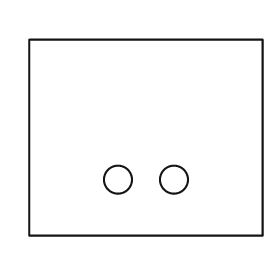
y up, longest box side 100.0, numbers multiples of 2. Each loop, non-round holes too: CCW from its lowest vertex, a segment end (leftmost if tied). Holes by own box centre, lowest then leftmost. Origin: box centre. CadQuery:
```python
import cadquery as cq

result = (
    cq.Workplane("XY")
    .moveTo(-50.0, -42.0)
    .lineTo(50.0, -42.0)
    .lineTo(50.0, 42.0)
    .lineTo(-50.0, 42.0)
    .close()
    .moveTo(-12.0, -18.0)
    .circle(6.0)
    .moveTo(12.0, -18.0)
    .circle(6.0)
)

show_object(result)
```